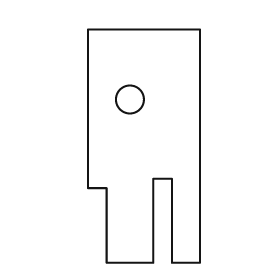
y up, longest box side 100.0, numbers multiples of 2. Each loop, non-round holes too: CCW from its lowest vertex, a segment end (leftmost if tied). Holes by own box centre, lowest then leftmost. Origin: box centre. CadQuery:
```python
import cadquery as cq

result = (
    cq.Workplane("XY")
    .moveTo(-16.0, -50.0)
    .lineTo(4.0, -50.0)
    .lineTo(4.0, -14.0)
    .lineTo(12.0, -14.0)
    .lineTo(12.0, -50.0)
    .lineTo(24.0, -50.0)
    .lineTo(24.0, 50.0)
    .lineTo(-24.0, 50.0)
    .lineTo(-24.0, -18.0)
    .lineTo(-16.0, -18.0)
    .close()
    .moveTo(-6.0, 20.0)
    .circle(6.0)
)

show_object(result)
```